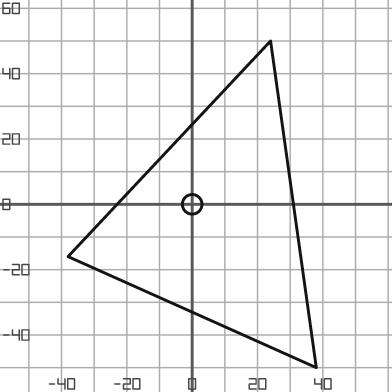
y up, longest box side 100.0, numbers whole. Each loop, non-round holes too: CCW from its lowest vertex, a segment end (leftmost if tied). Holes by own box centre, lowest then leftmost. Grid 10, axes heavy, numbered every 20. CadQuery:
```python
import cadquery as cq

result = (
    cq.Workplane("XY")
    .moveTo(38.0, -50.0)
    .lineTo(24.0, 50.0)
    .lineTo(-38.0, -16.0)
    .close()
    .moveTo(0.0, 0.0)
    .circle(3.0)
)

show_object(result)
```